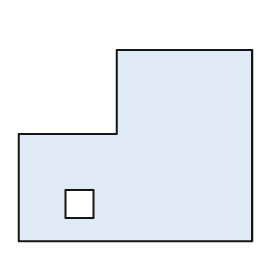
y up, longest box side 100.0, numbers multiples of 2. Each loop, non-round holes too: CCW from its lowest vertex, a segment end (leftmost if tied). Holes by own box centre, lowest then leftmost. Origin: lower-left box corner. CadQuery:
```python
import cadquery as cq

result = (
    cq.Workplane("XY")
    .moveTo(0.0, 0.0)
    .lineTo(100.0, 0.0)
    .lineTo(100.0, 82.0)
    .lineTo(42.0, 82.0)
    .lineTo(42.0, 46.0)
    .lineTo(0.0, 46.0)
    .close()
    .moveTo(20.0, 10.0)
    .lineTo(32.0, 10.0)
    .lineTo(32.0, 22.0)
    .lineTo(20.0, 22.0)
    .close()
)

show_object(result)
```